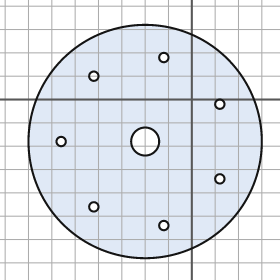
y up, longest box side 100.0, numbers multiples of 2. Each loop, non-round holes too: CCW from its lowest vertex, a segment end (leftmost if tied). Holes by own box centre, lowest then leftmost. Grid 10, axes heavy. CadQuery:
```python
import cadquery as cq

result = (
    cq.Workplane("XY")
    .moveTo(-20.0, -18.0)
    .circle(50.0)
    .moveTo(-12.0, -54.0)
    .circle(2.0)
    .moveTo(-42.0, -46.0)
    .circle(2.0)
    .moveTo(12.0, -34.0)
    .circle(2.0)
    .moveTo(-56.0, -18.0)
    .circle(2.0)
    .moveTo(-20.0, -18.0)
    .circle(6.0)
    .moveTo(12.0, -2.0)
    .circle(2.0)
    .moveTo(-42.0, 10.0)
    .circle(2.0)
    .moveTo(-12.0, 18.0)
    .circle(2.0)
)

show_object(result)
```